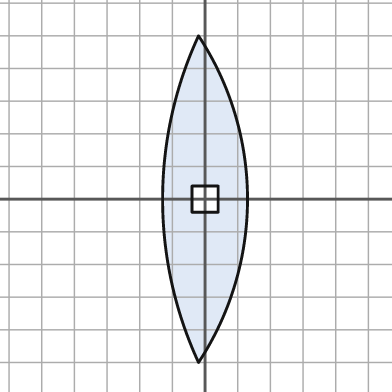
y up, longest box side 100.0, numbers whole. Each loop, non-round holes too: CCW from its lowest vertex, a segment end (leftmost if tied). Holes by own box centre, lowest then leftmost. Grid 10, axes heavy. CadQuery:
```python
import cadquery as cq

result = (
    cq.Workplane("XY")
    .moveTo(-2.0, -50.0)
    .threePointArc((13.0, 0.0), (-2.0, 50.0))
    .threePointArc((-13.0, 0.0), (-2.0, -50.0))
    .close()
    .moveTo(-4.0, -4.0)
    .lineTo(4.0, -4.0)
    .lineTo(4.0, 4.0)
    .lineTo(-4.0, 4.0)
    .close()
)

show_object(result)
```